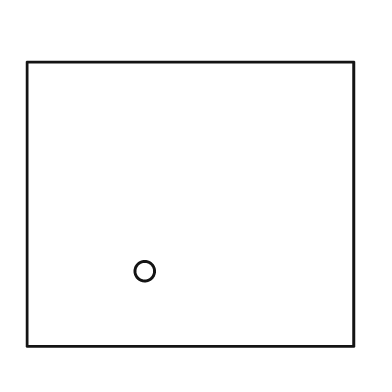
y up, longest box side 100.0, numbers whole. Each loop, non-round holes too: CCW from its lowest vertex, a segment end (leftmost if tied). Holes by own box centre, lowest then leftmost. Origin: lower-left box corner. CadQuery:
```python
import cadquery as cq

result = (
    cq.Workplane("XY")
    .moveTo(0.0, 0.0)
    .lineTo(100.0, 0.0)
    .lineTo(100.0, 87.0)
    .lineTo(0.0, 87.0)
    .close()
    .moveTo(36.0, 23.0)
    .circle(3.0)
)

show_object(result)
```